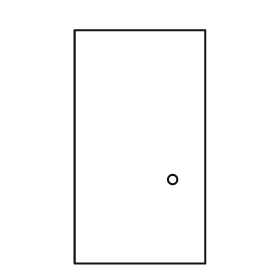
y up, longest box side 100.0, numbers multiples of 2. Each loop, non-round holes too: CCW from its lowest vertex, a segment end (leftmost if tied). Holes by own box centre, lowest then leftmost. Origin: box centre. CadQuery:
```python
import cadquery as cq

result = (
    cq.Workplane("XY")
    .moveTo(-28.0, -50.0)
    .lineTo(28.0, -50.0)
    .lineTo(28.0, 50.0)
    .lineTo(-28.0, 50.0)
    .close()
    .moveTo(14.0, -14.0)
    .circle(2.0)
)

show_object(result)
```